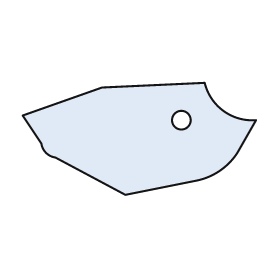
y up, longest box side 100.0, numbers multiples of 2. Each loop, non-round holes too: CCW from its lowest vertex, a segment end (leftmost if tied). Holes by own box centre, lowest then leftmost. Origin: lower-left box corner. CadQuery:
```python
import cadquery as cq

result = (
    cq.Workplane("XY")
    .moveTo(44.0, 0.0)
    .lineTo(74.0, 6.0)
    .threePointArc((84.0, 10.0), (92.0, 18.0))
    .lineTo(100.0, 32.0)
    .threePointArc((86.0, 36.0), (78.0, 48.0))
    .lineTo(34.0, 46.0)
    .lineTo(0.0, 34.0)
    .lineTo(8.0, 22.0)
    .threePointArc((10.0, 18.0), (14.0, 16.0))
    .close()
    .moveTo(68.0, 32.0)
    .circle(4.0)
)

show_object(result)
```